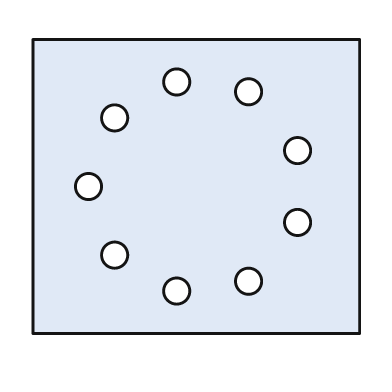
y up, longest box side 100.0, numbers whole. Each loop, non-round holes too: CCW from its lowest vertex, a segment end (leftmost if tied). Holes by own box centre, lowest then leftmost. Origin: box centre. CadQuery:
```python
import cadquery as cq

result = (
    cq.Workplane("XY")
    .moveTo(-50.0, -45.0)
    .lineTo(50.0, -45.0)
    .lineTo(50.0, 45.0)
    .lineTo(-50.0, 45.0)
    .close()
    .moveTo(-6.0, -32.0)
    .circle(4.0)
    .moveTo(16.0, -29.0)
    .circle(4.0)
    .moveTo(-25.0, -21.0)
    .circle(4.0)
    .moveTo(31.0, -11.0)
    .circle(4.0)
    .moveTo(-33.0, 0.0)
    .circle(4.0)
    .moveTo(31.0, 11.0)
    .circle(4.0)
    .moveTo(-25.0, 21.0)
    .circle(4.0)
    .moveTo(16.0, 29.0)
    .circle(4.0)
    .moveTo(-6.0, 32.0)
    .circle(4.0)
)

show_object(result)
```